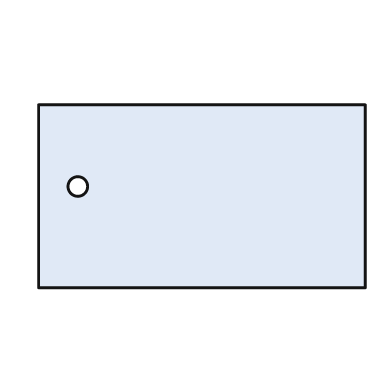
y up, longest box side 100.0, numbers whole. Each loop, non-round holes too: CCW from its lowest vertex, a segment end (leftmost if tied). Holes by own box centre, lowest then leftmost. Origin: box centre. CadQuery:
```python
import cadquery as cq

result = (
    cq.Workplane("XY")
    .moveTo(-50.0, -28.0)
    .lineTo(50.0, -28.0)
    .lineTo(50.0, 28.0)
    .lineTo(-50.0, 28.0)
    .close()
    .moveTo(-38.0, 3.0)
    .circle(3.0)
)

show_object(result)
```